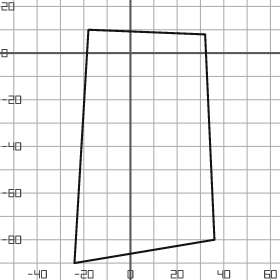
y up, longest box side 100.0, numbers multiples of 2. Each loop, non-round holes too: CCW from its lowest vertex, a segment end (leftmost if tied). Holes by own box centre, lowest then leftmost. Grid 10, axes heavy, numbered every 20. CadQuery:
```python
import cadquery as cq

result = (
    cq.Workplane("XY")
    .moveTo(-24.0, -90.0)
    .lineTo(36.0, -80.0)
    .lineTo(32.0, 8.0)
    .lineTo(-18.0, 10.0)
    .close()
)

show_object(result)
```